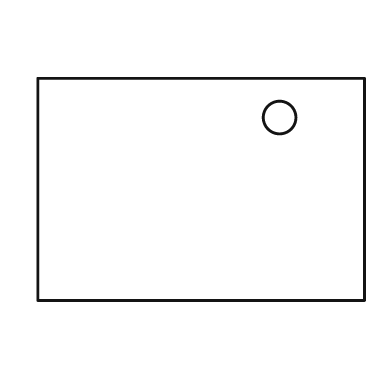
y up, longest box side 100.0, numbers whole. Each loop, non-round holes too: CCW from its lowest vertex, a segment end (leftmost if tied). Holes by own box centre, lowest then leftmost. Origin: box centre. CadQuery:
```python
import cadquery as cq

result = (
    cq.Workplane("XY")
    .moveTo(-50.0, -34.0)
    .lineTo(50.0, -34.0)
    .lineTo(50.0, 34.0)
    .lineTo(-50.0, 34.0)
    .close()
    .moveTo(24.0, 22.0)
    .circle(5.0)
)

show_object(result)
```